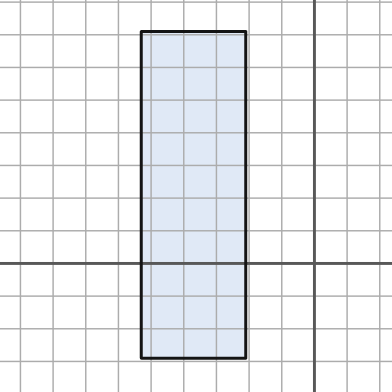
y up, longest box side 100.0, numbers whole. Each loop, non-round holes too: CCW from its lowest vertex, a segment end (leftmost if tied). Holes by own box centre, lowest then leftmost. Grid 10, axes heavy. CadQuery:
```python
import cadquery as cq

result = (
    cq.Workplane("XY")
    .moveTo(-53.0, -29.0)
    .lineTo(-21.0, -29.0)
    .lineTo(-21.0, 71.0)
    .lineTo(-53.0, 71.0)
    .close()
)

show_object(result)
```